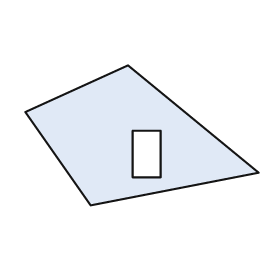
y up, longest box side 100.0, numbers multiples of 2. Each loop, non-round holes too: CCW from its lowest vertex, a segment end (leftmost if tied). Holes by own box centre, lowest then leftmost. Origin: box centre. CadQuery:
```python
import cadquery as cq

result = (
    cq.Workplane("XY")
    .moveTo(-22.0, -30.0)
    .lineTo(50.0, -16.0)
    .lineTo(-6.0, 30.0)
    .lineTo(-50.0, 10.0)
    .close()
    .moveTo(-4.0, -18.0)
    .lineTo(8.0, -18.0)
    .lineTo(8.0, 2.0)
    .lineTo(-4.0, 2.0)
    .close()
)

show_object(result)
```